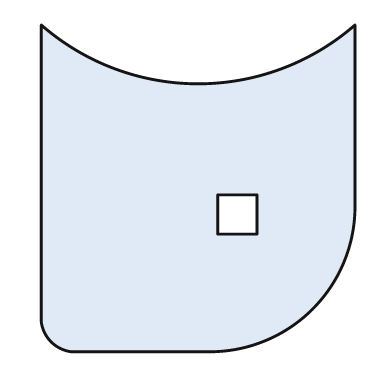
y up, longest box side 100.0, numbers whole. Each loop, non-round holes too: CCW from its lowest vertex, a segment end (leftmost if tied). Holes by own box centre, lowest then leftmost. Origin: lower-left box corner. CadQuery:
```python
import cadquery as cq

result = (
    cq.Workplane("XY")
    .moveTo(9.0, 0.0)
    .lineTo(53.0, 0.0)
    .threePointArc((83.0, 13.0), (96.0, 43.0))
    .lineTo(96.0, 100.0)
    .threePointArc((48.0, 82.0), (0.0, 100.0))
    .lineTo(0.0, 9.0)
    .threePointArc((3.0, 3.0), (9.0, 0.0))
    .close()
    .moveTo(54.0, 36.0)
    .lineTo(66.0, 36.0)
    .lineTo(66.0, 48.0)
    .lineTo(54.0, 48.0)
    .close()
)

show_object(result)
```